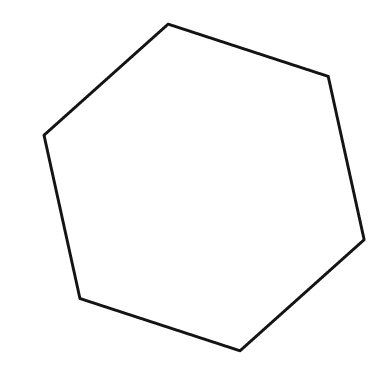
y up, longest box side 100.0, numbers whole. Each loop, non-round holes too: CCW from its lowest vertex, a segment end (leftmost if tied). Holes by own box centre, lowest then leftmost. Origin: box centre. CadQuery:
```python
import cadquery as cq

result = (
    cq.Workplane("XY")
    .moveTo(11.0, -50.0)
    .lineTo(49.0, -16.0)
    .lineTo(38.0, 34.0)
    .lineTo(-11.0, 50.0)
    .lineTo(-49.0, 16.0)
    .lineTo(-38.0, -34.0)
    .close()
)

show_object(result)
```